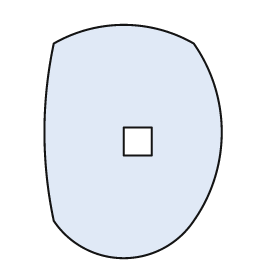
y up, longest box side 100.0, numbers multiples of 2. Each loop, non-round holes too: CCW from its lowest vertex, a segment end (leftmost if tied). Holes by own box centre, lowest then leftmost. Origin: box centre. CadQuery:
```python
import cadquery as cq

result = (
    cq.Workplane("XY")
    .moveTo(-34.0, -34.0)
    .threePointArc((-4.0, -50.0), (26.0, -34.0))
    .threePointArc((38.0, 4.0), (26.0, 42.0))
    .threePointArc((-4.0, 50.0), (-34.0, 42.0))
    .threePointArc((-38.0, 4.0), (-34.0, -34.0))
    .close()
    .moveTo(-4.0, -6.0)
    .lineTo(8.0, -6.0)
    .lineTo(8.0, 6.0)
    .lineTo(-4.0, 6.0)
    .close()
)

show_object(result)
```